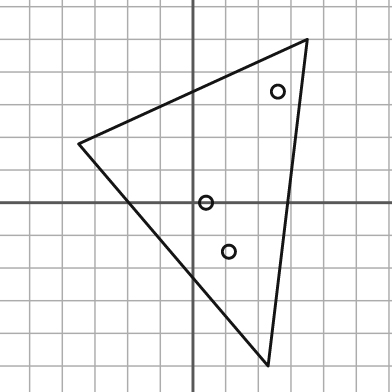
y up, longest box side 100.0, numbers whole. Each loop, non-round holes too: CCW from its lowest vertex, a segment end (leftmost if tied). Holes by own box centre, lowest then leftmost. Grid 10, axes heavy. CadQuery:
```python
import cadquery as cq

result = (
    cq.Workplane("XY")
    .moveTo(23.0, -50.0)
    .lineTo(35.0, 50.0)
    .lineTo(-35.0, 18.0)
    .close()
    .moveTo(11.0, -15.0)
    .circle(2.0)
    .moveTo(4.0, 0.0)
    .circle(2.0)
    .moveTo(26.0, 34.0)
    .circle(2.0)
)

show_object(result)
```